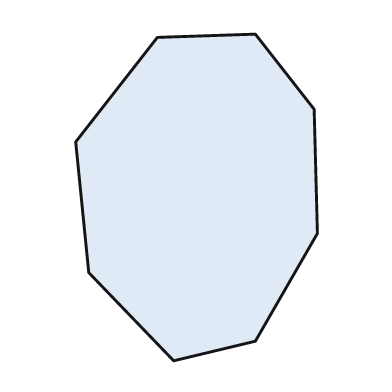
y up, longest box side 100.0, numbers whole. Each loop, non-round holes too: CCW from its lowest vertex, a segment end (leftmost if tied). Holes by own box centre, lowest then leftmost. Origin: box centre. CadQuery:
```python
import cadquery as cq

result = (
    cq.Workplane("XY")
    .moveTo(-7.0, -50.0)
    .lineTo(18.0, -44.0)
    .lineTo(37.0, -11.0)
    .lineTo(36.0, 27.0)
    .lineTo(18.0, 50.0)
    .lineTo(-12.0, 49.0)
    .lineTo(-37.0, 17.0)
    .lineTo(-33.0, -23.0)
    .close()
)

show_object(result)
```